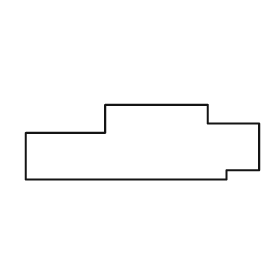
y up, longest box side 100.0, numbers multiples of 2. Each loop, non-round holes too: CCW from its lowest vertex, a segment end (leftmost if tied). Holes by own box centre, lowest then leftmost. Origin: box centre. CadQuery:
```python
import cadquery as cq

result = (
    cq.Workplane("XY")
    .moveTo(-50.0, -16.0)
    .lineTo(36.0, -16.0)
    .lineTo(36.0, -12.0)
    .lineTo(50.0, -12.0)
    .lineTo(50.0, 8.0)
    .lineTo(28.0, 8.0)
    .lineTo(28.0, 16.0)
    .lineTo(-16.0, 16.0)
    .lineTo(-16.0, 4.0)
    .lineTo(-50.0, 4.0)
    .close()
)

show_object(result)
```